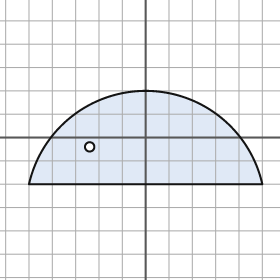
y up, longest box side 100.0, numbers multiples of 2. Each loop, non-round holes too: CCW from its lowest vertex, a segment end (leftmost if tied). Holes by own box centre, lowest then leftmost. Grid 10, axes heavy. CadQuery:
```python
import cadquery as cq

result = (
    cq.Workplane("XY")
    .moveTo(-50.0, -20.0)
    .lineTo(50.0, -20.0)
    .threePointArc((0.0, 20.0), (-50.0, -20.0))
    .close()
    .moveTo(-24.0, -4.0)
    .circle(2.0)
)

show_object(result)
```